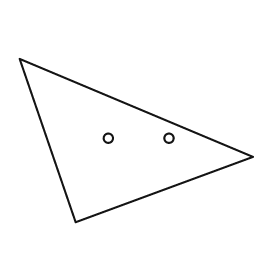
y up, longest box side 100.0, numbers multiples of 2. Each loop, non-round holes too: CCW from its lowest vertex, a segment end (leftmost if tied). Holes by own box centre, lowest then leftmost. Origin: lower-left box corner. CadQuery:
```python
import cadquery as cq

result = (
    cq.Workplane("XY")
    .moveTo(24.0, 0.0)
    .lineTo(100.0, 28.0)
    .lineTo(0.0, 70.0)
    .close()
    .moveTo(38.0, 36.0)
    .circle(2.0)
    .moveTo(64.0, 36.0)
    .circle(2.0)
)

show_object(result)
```